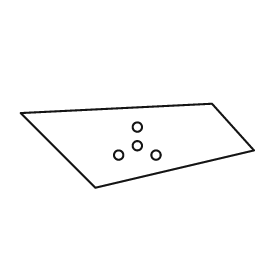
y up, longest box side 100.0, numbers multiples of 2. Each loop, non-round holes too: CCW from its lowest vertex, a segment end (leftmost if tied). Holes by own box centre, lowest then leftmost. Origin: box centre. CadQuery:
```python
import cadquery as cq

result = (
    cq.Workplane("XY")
    .moveTo(-18.0, -18.0)
    .lineTo(50.0, -2.0)
    .lineTo(32.0, 18.0)
    .lineTo(-50.0, 14.0)
    .close()
    .moveTo(-8.0, -4.0)
    .circle(2.0)
    .moveTo(8.0, -4.0)
    .circle(2.0)
    .moveTo(0.0, 0.0)
    .circle(2.0)
    .moveTo(0.0, 8.0)
    .circle(2.0)
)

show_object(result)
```